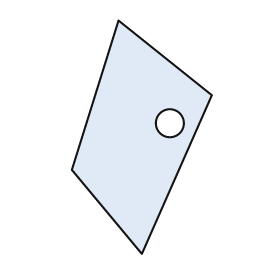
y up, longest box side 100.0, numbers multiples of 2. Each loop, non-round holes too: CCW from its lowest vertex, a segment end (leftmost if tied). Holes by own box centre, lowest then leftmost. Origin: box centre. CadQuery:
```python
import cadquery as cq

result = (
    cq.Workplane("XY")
    .moveTo(0.0, -50.0)
    .lineTo(30.0, 18.0)
    .lineTo(-10.0, 50.0)
    .lineTo(-30.0, -14.0)
    .close()
    .moveTo(12.0, 6.0)
    .circle(6.0)
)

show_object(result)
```